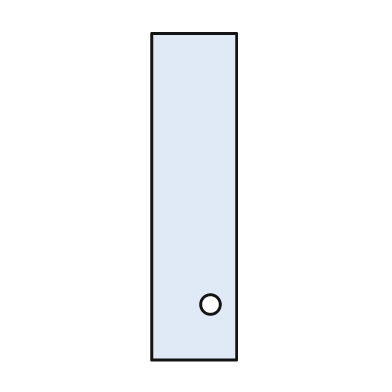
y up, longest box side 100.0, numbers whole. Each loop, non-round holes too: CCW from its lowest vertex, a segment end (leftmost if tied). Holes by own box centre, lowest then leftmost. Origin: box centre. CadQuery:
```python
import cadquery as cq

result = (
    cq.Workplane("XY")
    .moveTo(-13.0, -50.0)
    .lineTo(13.0, -50.0)
    .lineTo(13.0, 50.0)
    .lineTo(-13.0, 50.0)
    .close()
    .moveTo(5.0, -33.0)
    .circle(3.0)
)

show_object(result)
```